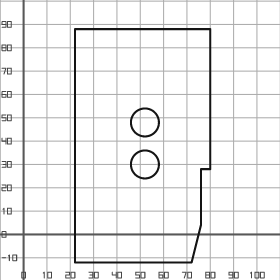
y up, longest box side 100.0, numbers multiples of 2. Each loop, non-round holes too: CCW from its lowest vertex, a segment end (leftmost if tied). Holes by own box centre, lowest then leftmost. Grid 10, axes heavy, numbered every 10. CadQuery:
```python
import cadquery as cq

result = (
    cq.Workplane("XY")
    .moveTo(22.0, -12.0)
    .lineTo(72.0, -12.0)
    .lineTo(76.0, 4.0)
    .lineTo(76.0, 28.0)
    .lineTo(80.0, 28.0)
    .lineTo(80.0, 88.0)
    .lineTo(22.0, 88.0)
    .close()
    .moveTo(52.0, 30.0)
    .circle(6.0)
    .moveTo(52.0, 48.0)
    .circle(6.0)
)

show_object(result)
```